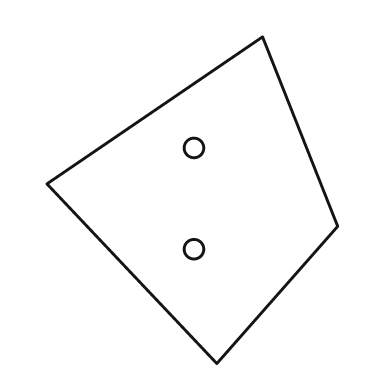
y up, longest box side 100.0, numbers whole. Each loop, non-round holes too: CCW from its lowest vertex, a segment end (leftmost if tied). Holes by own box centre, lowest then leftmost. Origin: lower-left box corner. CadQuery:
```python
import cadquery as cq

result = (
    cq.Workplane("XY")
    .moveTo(52.0, 0.0)
    .lineTo(89.0, 42.0)
    .lineTo(66.0, 100.0)
    .lineTo(0.0, 55.0)
    .close()
    .moveTo(45.0, 35.0)
    .circle(3.0)
    .moveTo(45.0, 66.0)
    .circle(3.0)
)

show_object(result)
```